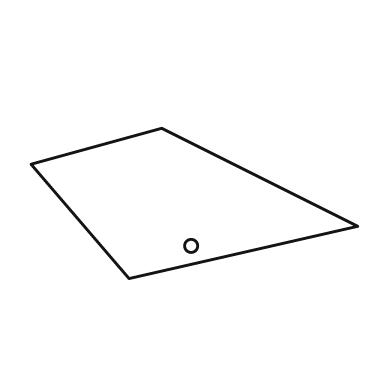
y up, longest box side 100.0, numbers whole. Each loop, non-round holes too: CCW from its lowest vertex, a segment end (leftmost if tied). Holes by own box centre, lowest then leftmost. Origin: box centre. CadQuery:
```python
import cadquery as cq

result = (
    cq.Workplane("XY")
    .moveTo(-20.0, -23.0)
    .lineTo(50.0, -7.0)
    .lineTo(-10.0, 23.0)
    .lineTo(-50.0, 12.0)
    .close()
    .moveTo(-1.0, -13.0)
    .circle(2.0)
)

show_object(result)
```